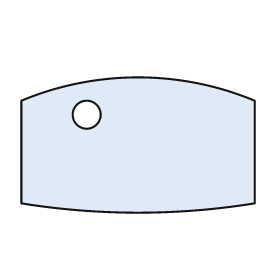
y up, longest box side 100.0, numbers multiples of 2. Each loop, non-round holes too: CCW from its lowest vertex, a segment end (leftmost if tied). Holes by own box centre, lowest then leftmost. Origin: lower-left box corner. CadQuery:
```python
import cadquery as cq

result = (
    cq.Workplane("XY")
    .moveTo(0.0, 4.0)
    .threePointArc((50.0, 0.0), (100.0, 4.0))
    .lineTo(100.0, 48.0)
    .threePointArc((50.0, 58.0), (0.0, 48.0))
    .close()
    .moveTo(28.0, 42.0)
    .circle(6.0)
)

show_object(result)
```